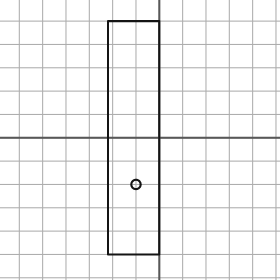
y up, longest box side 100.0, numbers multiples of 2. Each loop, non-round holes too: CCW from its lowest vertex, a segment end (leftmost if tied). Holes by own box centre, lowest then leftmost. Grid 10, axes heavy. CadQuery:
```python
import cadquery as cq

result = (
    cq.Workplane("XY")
    .moveTo(-22.0, -50.0)
    .lineTo(0.0, -50.0)
    .lineTo(0.0, 50.0)
    .lineTo(-22.0, 50.0)
    .close()
    .moveTo(-10.0, -20.0)
    .circle(2.0)
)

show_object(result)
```